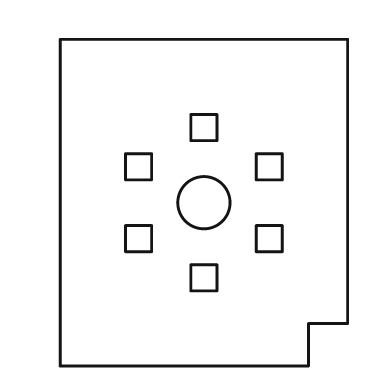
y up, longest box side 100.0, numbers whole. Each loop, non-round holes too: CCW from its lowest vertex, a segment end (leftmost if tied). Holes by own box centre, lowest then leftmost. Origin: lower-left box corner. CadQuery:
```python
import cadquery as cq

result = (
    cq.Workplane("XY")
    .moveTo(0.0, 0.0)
    .lineTo(76.0, 0.0)
    .lineTo(76.0, 13.0)
    .lineTo(88.0, 13.0)
    .lineTo(88.0, 100.0)
    .lineTo(0.0, 100.0)
    .close()
    .moveTo(40.0, 23.0)
    .lineTo(48.0, 23.0)
    .lineTo(48.0, 31.0)
    .lineTo(40.0, 31.0)
    .close()
    .moveTo(20.0, 35.0)
    .lineTo(28.0, 35.0)
    .lineTo(28.0, 43.0)
    .lineTo(20.0, 43.0)
    .close()
    .moveTo(60.0, 35.0)
    .lineTo(68.0, 35.0)
    .lineTo(68.0, 43.0)
    .lineTo(60.0, 43.0)
    .close()
    .moveTo(44.0, 50.0)
    .circle(8.0)
    .moveTo(20.0, 57.0)
    .lineTo(28.0, 57.0)
    .lineTo(28.0, 65.0)
    .lineTo(20.0, 65.0)
    .close()
    .moveTo(60.0, 57.0)
    .lineTo(68.0, 57.0)
    .lineTo(68.0, 65.0)
    .lineTo(60.0, 65.0)
    .close()
    .moveTo(40.0, 69.0)
    .lineTo(48.0, 69.0)
    .lineTo(48.0, 77.0)
    .lineTo(40.0, 77.0)
    .close()
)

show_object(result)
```